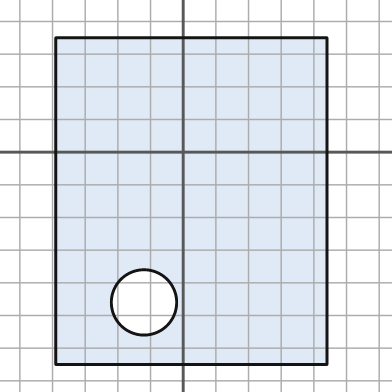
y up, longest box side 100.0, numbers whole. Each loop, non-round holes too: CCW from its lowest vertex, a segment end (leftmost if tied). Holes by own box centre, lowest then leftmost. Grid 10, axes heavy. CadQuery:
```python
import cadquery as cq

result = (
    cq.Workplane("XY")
    .moveTo(-39.0, -65.0)
    .lineTo(44.0, -65.0)
    .lineTo(44.0, 35.0)
    .lineTo(-39.0, 35.0)
    .close()
    .moveTo(-12.0, -46.0)
    .circle(10.0)
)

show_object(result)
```